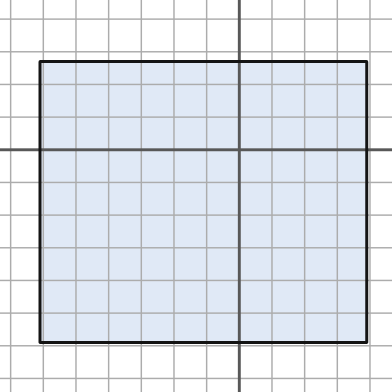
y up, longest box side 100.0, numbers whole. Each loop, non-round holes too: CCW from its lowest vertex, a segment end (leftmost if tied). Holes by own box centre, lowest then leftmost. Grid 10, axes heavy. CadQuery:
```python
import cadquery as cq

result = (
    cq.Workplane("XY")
    .moveTo(-61.0, -59.0)
    .lineTo(39.0, -59.0)
    .lineTo(39.0, 27.0)
    .lineTo(-61.0, 27.0)
    .close()
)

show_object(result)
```